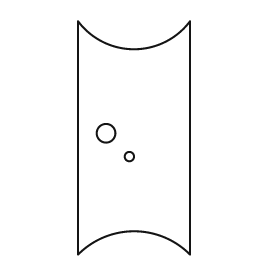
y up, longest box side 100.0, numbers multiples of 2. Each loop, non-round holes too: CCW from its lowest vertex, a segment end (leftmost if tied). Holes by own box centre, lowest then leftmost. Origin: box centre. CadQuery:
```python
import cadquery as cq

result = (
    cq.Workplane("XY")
    .moveTo(-24.0, -50.0)
    .threePointArc((0.0, -40.0), (24.0, -50.0))
    .lineTo(24.0, 50.0)
    .threePointArc((0.0, 38.0), (-24.0, 50.0))
    .close()
    .moveTo(-2.0, -8.0)
    .circle(2.0)
    .moveTo(-12.0, 2.0)
    .circle(4.0)
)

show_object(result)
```